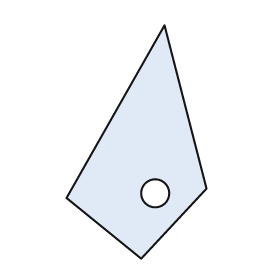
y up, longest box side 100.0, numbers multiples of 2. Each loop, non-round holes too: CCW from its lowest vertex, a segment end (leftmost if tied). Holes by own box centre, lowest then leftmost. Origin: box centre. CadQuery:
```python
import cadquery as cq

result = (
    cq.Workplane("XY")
    .moveTo(2.0, -50.0)
    .lineTo(30.0, -20.0)
    .lineTo(12.0, 50.0)
    .lineTo(-30.0, -24.0)
    .close()
    .moveTo(8.0, -22.0)
    .circle(6.0)
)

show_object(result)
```